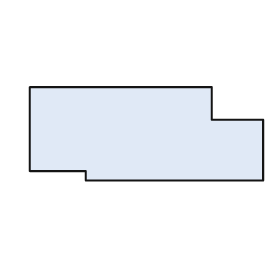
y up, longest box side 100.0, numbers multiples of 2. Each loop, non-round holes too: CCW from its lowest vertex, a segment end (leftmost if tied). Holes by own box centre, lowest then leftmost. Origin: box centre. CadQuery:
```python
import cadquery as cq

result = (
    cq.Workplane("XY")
    .moveTo(-26.0, -20.0)
    .lineTo(50.0, -20.0)
    .lineTo(50.0, 6.0)
    .lineTo(28.0, 6.0)
    .lineTo(28.0, 20.0)
    .lineTo(-50.0, 20.0)
    .lineTo(-50.0, -16.0)
    .lineTo(-26.0, -16.0)
    .close()
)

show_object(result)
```